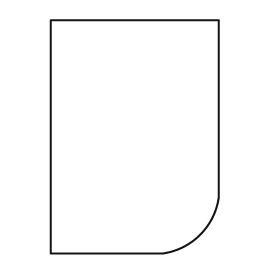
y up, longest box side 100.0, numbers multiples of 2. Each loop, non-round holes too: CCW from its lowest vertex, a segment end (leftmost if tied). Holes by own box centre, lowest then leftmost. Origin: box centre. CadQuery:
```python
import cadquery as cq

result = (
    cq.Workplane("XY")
    .moveTo(-36.0, -50.0)
    .lineTo(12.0, -50.0)
    .threePointArc((28.0, -42.0), (36.0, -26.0))
    .lineTo(36.0, 50.0)
    .lineTo(-36.0, 50.0)
    .close()
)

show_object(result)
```